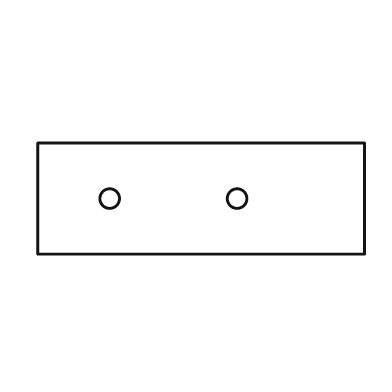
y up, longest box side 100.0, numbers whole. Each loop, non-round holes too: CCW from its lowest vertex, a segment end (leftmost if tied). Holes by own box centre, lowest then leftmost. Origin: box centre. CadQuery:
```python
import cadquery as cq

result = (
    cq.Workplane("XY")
    .moveTo(-50.0, -17.0)
    .lineTo(50.0, -17.0)
    .lineTo(50.0, 17.0)
    .lineTo(-50.0, 17.0)
    .close()
    .moveTo(-28.0, 0.0)
    .circle(3.0)
    .moveTo(11.0, 0.0)
    .circle(3.0)
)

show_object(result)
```